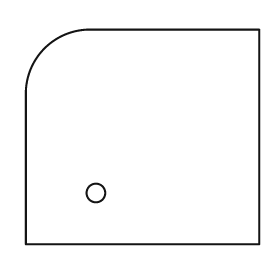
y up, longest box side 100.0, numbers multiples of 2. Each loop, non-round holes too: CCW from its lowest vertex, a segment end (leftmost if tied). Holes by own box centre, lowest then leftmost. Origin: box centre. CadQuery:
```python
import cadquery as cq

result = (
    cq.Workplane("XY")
    .moveTo(-50.0, -46.0)
    .lineTo(50.0, -46.0)
    .lineTo(50.0, 46.0)
    .lineTo(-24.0, 46.0)
    .threePointArc((-42.0, 38.0), (-50.0, 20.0))
    .close()
    .moveTo(-20.0, -24.0)
    .circle(4.0)
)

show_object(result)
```